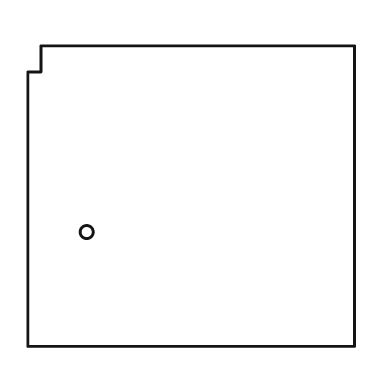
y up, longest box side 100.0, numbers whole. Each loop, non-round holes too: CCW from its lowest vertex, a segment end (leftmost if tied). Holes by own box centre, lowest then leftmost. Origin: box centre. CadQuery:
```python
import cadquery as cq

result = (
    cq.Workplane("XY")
    .moveTo(-50.0, -46.0)
    .lineTo(50.0, -46.0)
    .lineTo(50.0, 46.0)
    .lineTo(-46.0, 46.0)
    .lineTo(-46.0, 38.0)
    .lineTo(-50.0, 38.0)
    .close()
    .moveTo(-32.0, -11.0)
    .circle(2.0)
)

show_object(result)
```